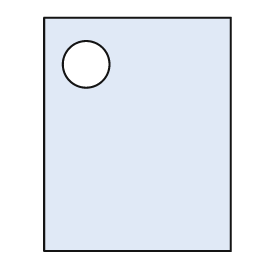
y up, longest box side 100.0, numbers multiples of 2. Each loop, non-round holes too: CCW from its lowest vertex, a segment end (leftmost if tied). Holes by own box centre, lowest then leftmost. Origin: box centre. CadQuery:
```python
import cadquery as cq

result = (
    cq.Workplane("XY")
    .moveTo(-40.0, -50.0)
    .lineTo(40.0, -50.0)
    .lineTo(40.0, 50.0)
    .lineTo(-40.0, 50.0)
    .close()
    .moveTo(-22.0, 30.0)
    .circle(10.0)
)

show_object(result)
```